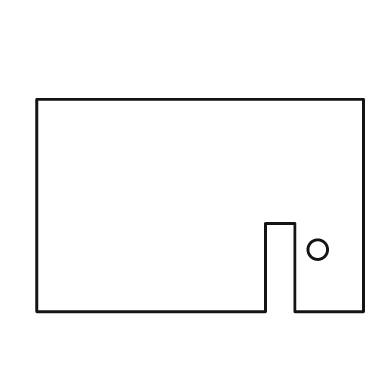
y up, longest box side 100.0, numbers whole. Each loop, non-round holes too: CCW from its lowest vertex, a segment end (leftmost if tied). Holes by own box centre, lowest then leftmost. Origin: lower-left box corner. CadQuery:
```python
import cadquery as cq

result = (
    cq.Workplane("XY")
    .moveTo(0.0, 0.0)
    .lineTo(70.0, 0.0)
    .lineTo(70.0, 27.0)
    .lineTo(79.0, 27.0)
    .lineTo(79.0, 0.0)
    .lineTo(100.0, 0.0)
    .lineTo(100.0, 65.0)
    .lineTo(0.0, 65.0)
    .close()
    .moveTo(86.0, 19.0)
    .circle(3.0)
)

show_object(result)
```